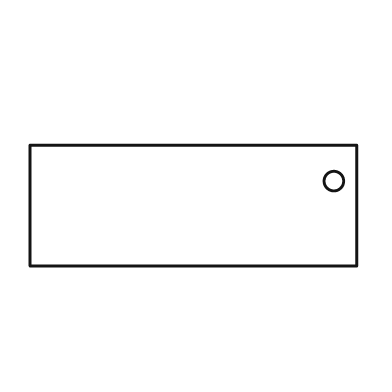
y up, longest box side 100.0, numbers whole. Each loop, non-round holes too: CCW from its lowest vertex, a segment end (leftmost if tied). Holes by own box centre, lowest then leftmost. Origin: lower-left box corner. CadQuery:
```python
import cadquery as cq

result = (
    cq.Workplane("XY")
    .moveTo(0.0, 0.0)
    .lineTo(100.0, 0.0)
    .lineTo(100.0, 37.0)
    .lineTo(0.0, 37.0)
    .close()
    .moveTo(93.0, 26.0)
    .circle(3.0)
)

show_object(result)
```